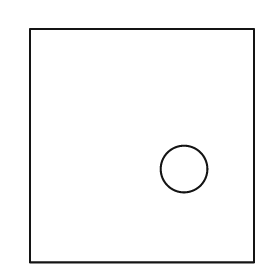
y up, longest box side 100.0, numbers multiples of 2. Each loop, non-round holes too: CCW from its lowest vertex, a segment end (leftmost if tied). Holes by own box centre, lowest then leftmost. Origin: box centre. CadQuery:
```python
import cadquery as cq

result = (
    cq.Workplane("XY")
    .moveTo(-48.0, -50.0)
    .lineTo(48.0, -50.0)
    .lineTo(48.0, 50.0)
    .lineTo(-48.0, 50.0)
    .close()
    .moveTo(18.0, -10.0)
    .circle(10.0)
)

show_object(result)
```